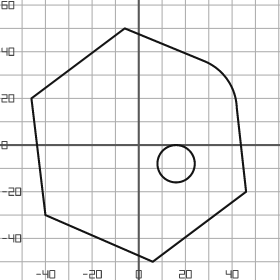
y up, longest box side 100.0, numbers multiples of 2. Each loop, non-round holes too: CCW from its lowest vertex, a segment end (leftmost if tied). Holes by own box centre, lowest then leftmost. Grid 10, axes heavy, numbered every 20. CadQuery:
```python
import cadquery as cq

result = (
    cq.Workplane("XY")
    .moveTo(6.0, -50.0)
    .lineTo(46.0, -20.0)
    .lineTo(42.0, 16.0)
    .threePointArc((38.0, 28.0), (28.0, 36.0))
    .lineTo(-6.0, 50.0)
    .lineTo(-46.0, 20.0)
    .lineTo(-40.0, -30.0)
    .close()
    .moveTo(16.0, -8.0)
    .circle(8.0)
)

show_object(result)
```